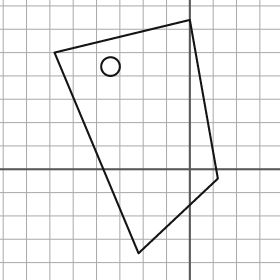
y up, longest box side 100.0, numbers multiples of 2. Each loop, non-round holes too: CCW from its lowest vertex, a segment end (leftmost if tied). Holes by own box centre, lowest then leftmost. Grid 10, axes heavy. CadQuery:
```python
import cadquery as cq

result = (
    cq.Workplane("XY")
    .moveTo(-22.0, -36.0)
    .lineTo(12.0, -4.0)
    .lineTo(0.0, 64.0)
    .lineTo(-58.0, 50.0)
    .close()
    .moveTo(-34.0, 44.0)
    .circle(4.0)
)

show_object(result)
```